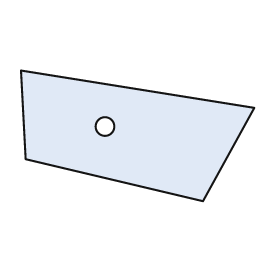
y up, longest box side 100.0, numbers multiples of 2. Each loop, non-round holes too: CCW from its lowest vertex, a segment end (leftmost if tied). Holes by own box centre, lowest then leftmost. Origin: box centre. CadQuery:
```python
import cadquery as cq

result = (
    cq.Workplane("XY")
    .moveTo(28.0, -28.0)
    .lineTo(50.0, 12.0)
    .lineTo(-50.0, 28.0)
    .lineTo(-48.0, -10.0)
    .close()
    .moveTo(-14.0, 4.0)
    .circle(4.0)
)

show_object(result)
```